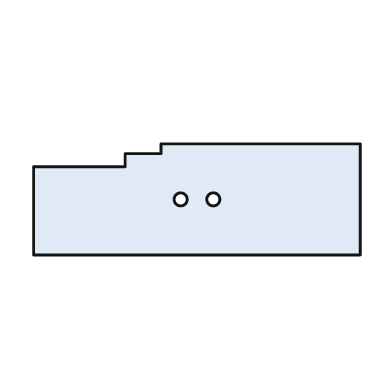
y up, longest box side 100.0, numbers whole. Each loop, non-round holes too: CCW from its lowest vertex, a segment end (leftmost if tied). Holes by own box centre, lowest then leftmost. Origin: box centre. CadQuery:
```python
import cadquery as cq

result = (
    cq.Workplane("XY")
    .moveTo(-50.0, -17.0)
    .lineTo(50.0, -17.0)
    .lineTo(50.0, 17.0)
    .lineTo(-11.0, 17.0)
    .lineTo(-11.0, 14.0)
    .lineTo(-22.0, 14.0)
    .lineTo(-22.0, 10.0)
    .lineTo(-50.0, 10.0)
    .close()
    .moveTo(-5.0, 0.0)
    .circle(2.0)
    .moveTo(5.0, 0.0)
    .circle(2.0)
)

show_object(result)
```